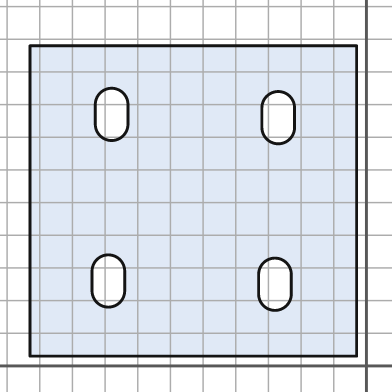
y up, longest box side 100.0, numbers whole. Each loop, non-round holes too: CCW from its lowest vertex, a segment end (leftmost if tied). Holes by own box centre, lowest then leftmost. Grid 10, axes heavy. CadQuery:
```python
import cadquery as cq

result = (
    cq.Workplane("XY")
    .moveTo(-103.0, 3.0)
    .lineTo(-3.0, 3.0)
    .lineTo(-3.0, 98.0)
    .lineTo(-103.0, 98.0)
    .close()
    .moveTo(-33.0, 22.0)
    .threePointArc((-28.0, 17.0), (-23.0, 22.0))
    .lineTo(-23.0, 28.0)
    .threePointArc((-28.0, 33.0), (-33.0, 28.0))
    .close()
    .moveTo(-84.0, 23.0)
    .threePointArc((-79.0, 18.0), (-74.0, 23.0))
    .lineTo(-74.0, 29.0)
    .threePointArc((-79.0, 34.0), (-84.0, 29.0))
    .close()
    .moveTo(-32.0, 73.0)
    .threePointArc((-27.0, 68.0), (-22.0, 73.0))
    .lineTo(-22.0, 79.0)
    .threePointArc((-27.0, 84.0), (-32.0, 79.0))
    .close()
    .moveTo(-83.0, 74.0)
    .threePointArc((-78.0, 69.0), (-73.0, 74.0))
    .lineTo(-73.0, 80.0)
    .threePointArc((-78.0, 85.0), (-83.0, 80.0))
    .close()
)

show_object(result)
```